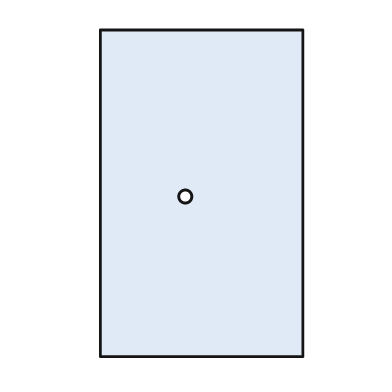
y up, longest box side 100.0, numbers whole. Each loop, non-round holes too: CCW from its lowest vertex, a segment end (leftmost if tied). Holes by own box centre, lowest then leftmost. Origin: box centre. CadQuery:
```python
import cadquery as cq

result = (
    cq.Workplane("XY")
    .moveTo(-31.0, -50.0)
    .lineTo(31.0, -50.0)
    .lineTo(31.0, 50.0)
    .lineTo(-31.0, 50.0)
    .close()
    .moveTo(-5.0, -1.0)
    .circle(2.0)
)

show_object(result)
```